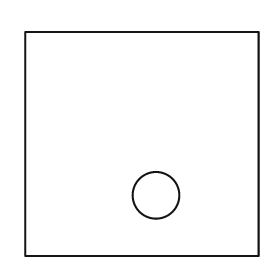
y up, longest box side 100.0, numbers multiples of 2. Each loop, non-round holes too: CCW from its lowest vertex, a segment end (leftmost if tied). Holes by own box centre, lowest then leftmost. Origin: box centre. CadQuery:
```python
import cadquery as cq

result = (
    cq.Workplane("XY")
    .moveTo(-50.0, -48.0)
    .lineTo(50.0, -48.0)
    .lineTo(50.0, 48.0)
    .lineTo(-50.0, 48.0)
    .close()
    .moveTo(6.0, -22.0)
    .circle(10.0)
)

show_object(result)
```